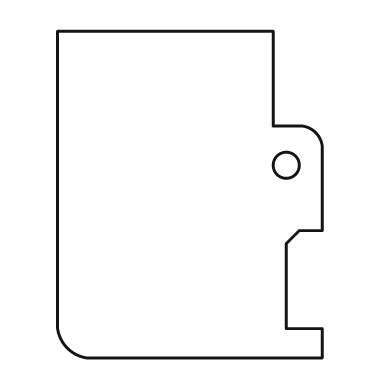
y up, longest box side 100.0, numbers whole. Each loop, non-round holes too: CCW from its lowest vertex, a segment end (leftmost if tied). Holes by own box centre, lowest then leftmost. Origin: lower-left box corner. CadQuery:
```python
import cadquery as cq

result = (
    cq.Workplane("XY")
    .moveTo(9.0, 0.0)
    .lineTo(81.0, 0.0)
    .lineTo(81.0, 9.0)
    .lineTo(70.0, 9.0)
    .lineTo(70.0, 35.0)
    .lineTo(74.0, 39.0)
    .lineTo(81.0, 39.0)
    .lineTo(81.0, 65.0)
    .threePointArc((79.0, 69.0), (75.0, 71.0))
    .lineTo(66.0, 71.0)
    .lineTo(66.0, 100.0)
    .lineTo(0.0, 100.0)
    .lineTo(0.0, 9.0)
    .threePointArc((3.0, 3.0), (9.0, 0.0))
    .close()
    .moveTo(70.0, 59.0)
    .circle(4.0)
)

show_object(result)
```